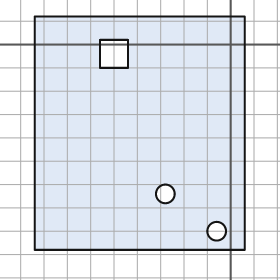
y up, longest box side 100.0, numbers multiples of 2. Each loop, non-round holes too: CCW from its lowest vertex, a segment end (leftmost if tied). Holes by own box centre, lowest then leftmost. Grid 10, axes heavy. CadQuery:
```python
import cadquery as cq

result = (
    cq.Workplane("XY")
    .moveTo(-84.0, -88.0)
    .lineTo(6.0, -88.0)
    .lineTo(6.0, 12.0)
    .lineTo(-84.0, 12.0)
    .close()
    .moveTo(-6.0, -80.0)
    .circle(4.0)
    .moveTo(-28.0, -64.0)
    .circle(4.0)
    .moveTo(-56.0, -10.0)
    .lineTo(-44.0, -10.0)
    .lineTo(-44.0, 2.0)
    .lineTo(-56.0, 2.0)
    .close()
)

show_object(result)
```